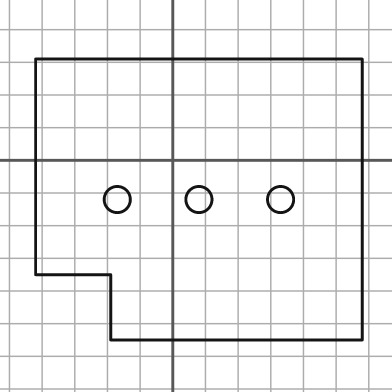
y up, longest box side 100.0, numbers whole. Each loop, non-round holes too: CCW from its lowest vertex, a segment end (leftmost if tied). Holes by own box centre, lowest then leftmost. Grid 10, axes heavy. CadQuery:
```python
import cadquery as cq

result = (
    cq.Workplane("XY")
    .moveTo(-19.0, -55.0)
    .lineTo(58.0, -55.0)
    .lineTo(58.0, 31.0)
    .lineTo(-42.0, 31.0)
    .lineTo(-42.0, -35.0)
    .lineTo(-19.0, -35.0)
    .close()
    .moveTo(-17.0, -12.0)
    .circle(4.0)
    .moveTo(8.0, -12.0)
    .circle(4.0)
    .moveTo(33.0, -12.0)
    .circle(4.0)
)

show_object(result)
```